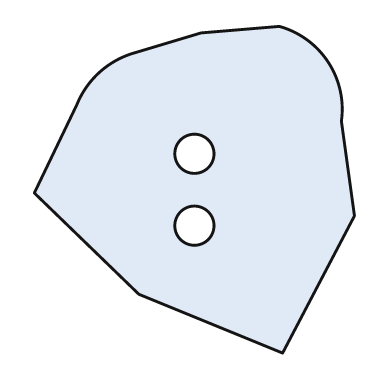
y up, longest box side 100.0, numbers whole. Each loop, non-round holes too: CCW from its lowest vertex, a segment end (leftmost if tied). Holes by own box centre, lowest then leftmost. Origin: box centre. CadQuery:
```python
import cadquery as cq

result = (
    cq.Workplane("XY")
    .moveTo(27.0, -50.0)
    .lineTo(49.0, -8.0)
    .lineTo(45.0, 21.0)
    .threePointArc((41.0, 39.0), (26.0, 50.0))
    .lineTo(2.0, 48.0)
    .lineTo(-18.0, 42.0)
    .threePointArc((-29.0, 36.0), (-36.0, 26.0))
    .lineTo(-49.0, -1.0)
    .lineTo(-17.0, -32.0)
    .close()
    .moveTo(0.0, -11.0)
    .circle(6.0)
    .moveTo(0.0, 11.0)
    .circle(6.0)
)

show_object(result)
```